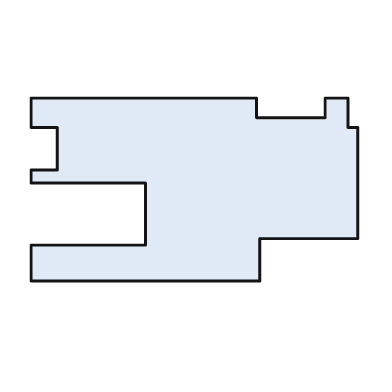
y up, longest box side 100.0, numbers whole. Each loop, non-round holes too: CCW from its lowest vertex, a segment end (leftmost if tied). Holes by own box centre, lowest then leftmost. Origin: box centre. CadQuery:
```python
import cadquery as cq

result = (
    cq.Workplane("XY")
    .moveTo(-50.0, -28.0)
    .lineTo(20.0, -28.0)
    .lineTo(20.0, -15.0)
    .lineTo(50.0, -15.0)
    .lineTo(50.0, 19.0)
    .lineTo(47.0, 19.0)
    .lineTo(47.0, 28.0)
    .lineTo(40.0, 28.0)
    .lineTo(40.0, 22.0)
    .lineTo(19.0, 22.0)
    .lineTo(19.0, 28.0)
    .lineTo(-50.0, 28.0)
    .lineTo(-50.0, 19.0)
    .lineTo(-42.0, 19.0)
    .lineTo(-42.0, 6.0)
    .lineTo(-50.0, 6.0)
    .lineTo(-50.0, 2.0)
    .lineTo(-15.0, 2.0)
    .lineTo(-15.0, -17.0)
    .lineTo(-50.0, -17.0)
    .close()
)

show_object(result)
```